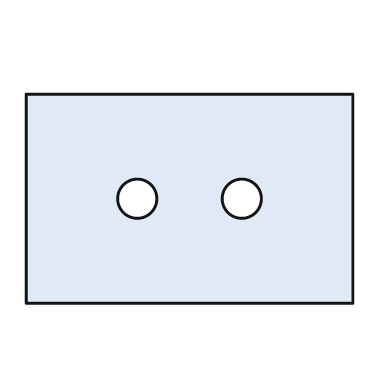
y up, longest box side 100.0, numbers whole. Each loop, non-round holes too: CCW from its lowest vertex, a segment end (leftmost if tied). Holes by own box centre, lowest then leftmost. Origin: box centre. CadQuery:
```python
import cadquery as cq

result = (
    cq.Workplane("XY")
    .moveTo(-50.0, -32.0)
    .lineTo(50.0, -32.0)
    .lineTo(50.0, 32.0)
    .lineTo(-50.0, 32.0)
    .close()
    .moveTo(-16.0, 0.0)
    .circle(6.0)
    .moveTo(16.0, 0.0)
    .circle(6.0)
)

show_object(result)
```